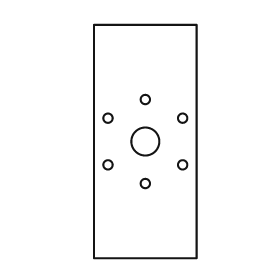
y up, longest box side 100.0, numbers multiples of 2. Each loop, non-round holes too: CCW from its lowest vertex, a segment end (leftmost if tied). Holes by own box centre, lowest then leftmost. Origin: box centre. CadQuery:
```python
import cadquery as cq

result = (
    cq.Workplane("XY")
    .moveTo(-22.0, -50.0)
    .lineTo(22.0, -50.0)
    .lineTo(22.0, 50.0)
    .lineTo(-22.0, 50.0)
    .close()
    .moveTo(0.0, -18.0)
    .circle(2.0)
    .moveTo(-16.0, -10.0)
    .circle(2.0)
    .moveTo(16.0, -10.0)
    .circle(2.0)
    .moveTo(0.0, 0.0)
    .circle(6.0)
    .moveTo(-16.0, 10.0)
    .circle(2.0)
    .moveTo(16.0, 10.0)
    .circle(2.0)
    .moveTo(0.0, 18.0)
    .circle(2.0)
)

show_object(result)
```